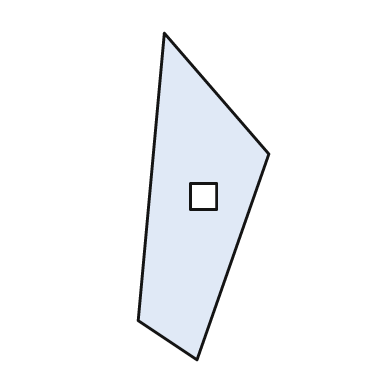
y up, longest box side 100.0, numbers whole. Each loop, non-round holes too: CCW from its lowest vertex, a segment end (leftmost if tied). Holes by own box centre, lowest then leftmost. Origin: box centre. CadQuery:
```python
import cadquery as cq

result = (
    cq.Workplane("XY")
    .moveTo(-2.0, -50.0)
    .lineTo(20.0, 13.0)
    .lineTo(-12.0, 50.0)
    .lineTo(-20.0, -38.0)
    .close()
    .moveTo(-4.0, -4.0)
    .lineTo(4.0, -4.0)
    .lineTo(4.0, 4.0)
    .lineTo(-4.0, 4.0)
    .close()
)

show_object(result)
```